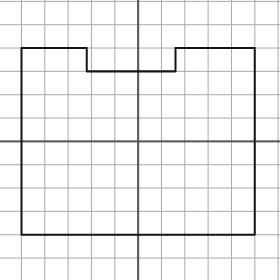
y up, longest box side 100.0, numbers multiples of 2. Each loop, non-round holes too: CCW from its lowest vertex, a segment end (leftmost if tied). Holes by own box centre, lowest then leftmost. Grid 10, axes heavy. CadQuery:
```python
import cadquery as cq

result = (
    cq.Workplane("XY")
    .moveTo(-50.0, -40.0)
    .lineTo(50.0, -40.0)
    .lineTo(50.0, 40.0)
    .lineTo(16.0, 40.0)
    .lineTo(16.0, 30.0)
    .lineTo(-22.0, 30.0)
    .lineTo(-22.0, 40.0)
    .lineTo(-50.0, 40.0)
    .close()
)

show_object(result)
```